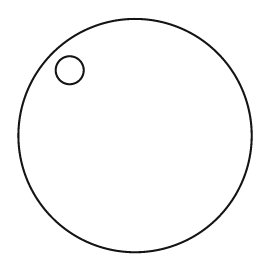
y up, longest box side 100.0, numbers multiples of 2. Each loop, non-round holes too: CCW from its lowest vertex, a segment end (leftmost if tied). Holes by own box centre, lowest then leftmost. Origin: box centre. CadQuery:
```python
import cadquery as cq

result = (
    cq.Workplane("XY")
    .moveTo(0.0, 0.0)
    .circle(50.0)
    .moveTo(-28.0, 28.0)
    .circle(6.0)
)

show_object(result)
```